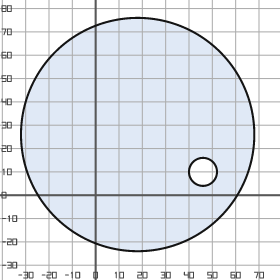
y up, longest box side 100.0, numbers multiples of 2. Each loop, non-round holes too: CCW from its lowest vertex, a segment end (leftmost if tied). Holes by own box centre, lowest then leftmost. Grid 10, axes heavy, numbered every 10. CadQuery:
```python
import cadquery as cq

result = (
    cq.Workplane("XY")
    .moveTo(18.0, 26.0)
    .circle(50.0)
    .moveTo(46.0, 10.0)
    .circle(6.0)
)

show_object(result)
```